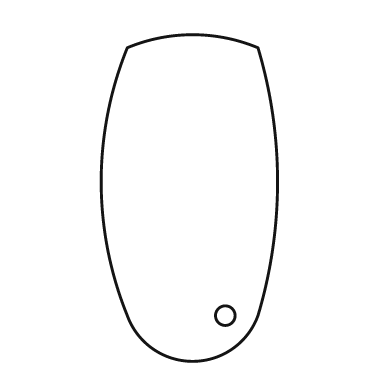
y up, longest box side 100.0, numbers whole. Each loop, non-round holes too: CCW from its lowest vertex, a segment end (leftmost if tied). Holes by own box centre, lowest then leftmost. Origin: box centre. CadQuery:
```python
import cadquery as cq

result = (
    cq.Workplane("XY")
    .moveTo(-19.0, -36.0)
    .threePointArc((1.0, -50.0), (21.0, -36.0))
    .threePointArc((27.0, 5.0), (21.0, 46.0))
    .threePointArc((1.0, 50.0), (-19.0, 46.0))
    .threePointArc((-27.0, 5.0), (-19.0, -36.0))
    .close()
    .moveTo(11.0, -36.0)
    .circle(3.0)
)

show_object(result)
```